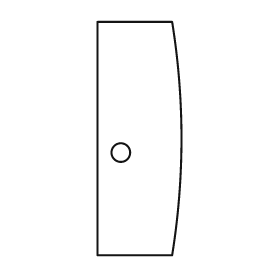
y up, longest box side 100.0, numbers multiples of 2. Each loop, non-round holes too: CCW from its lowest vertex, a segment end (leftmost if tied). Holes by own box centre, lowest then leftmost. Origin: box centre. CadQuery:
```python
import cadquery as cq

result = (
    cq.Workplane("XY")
    .moveTo(-18.0, -50.0)
    .lineTo(14.0, -50.0)
    .threePointArc((18.0, 0.0), (14.0, 50.0))
    .lineTo(-18.0, 50.0)
    .close()
    .moveTo(-8.0, -6.0)
    .circle(4.0)
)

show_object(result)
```